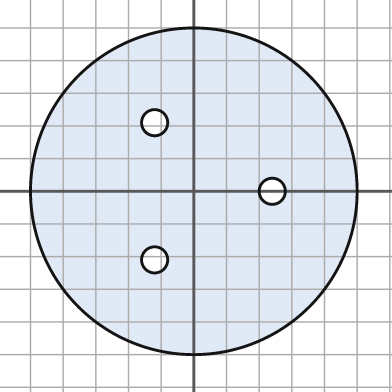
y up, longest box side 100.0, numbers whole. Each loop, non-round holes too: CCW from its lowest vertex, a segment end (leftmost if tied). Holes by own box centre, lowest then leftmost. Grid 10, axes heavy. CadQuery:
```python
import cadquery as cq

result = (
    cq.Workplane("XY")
    .moveTo(0.0, 0.0)
    .circle(50.0)
    .moveTo(-12.0, -21.0)
    .circle(4.0)
    .moveTo(24.0, 0.0)
    .circle(4.0)
    .moveTo(-12.0, 21.0)
    .circle(4.0)
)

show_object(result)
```